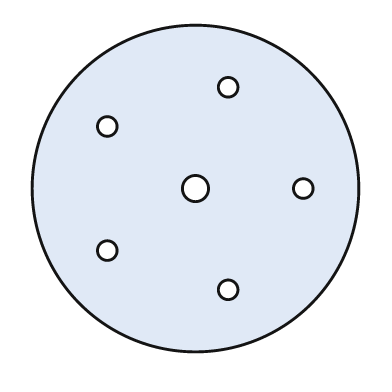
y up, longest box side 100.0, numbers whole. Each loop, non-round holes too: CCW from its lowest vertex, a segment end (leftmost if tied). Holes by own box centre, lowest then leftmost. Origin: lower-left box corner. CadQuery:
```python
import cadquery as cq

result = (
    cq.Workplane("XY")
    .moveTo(50.0, 50.0)
    .circle(50.0)
    .moveTo(60.0, 19.0)
    .circle(3.0)
    .moveTo(23.0, 31.0)
    .circle(3.0)
    .moveTo(50.0, 50.0)
    .circle(4.0)
    .moveTo(83.0, 50.0)
    .circle(3.0)
    .moveTo(23.0, 69.0)
    .circle(3.0)
    .moveTo(60.0, 81.0)
    .circle(3.0)
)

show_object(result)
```